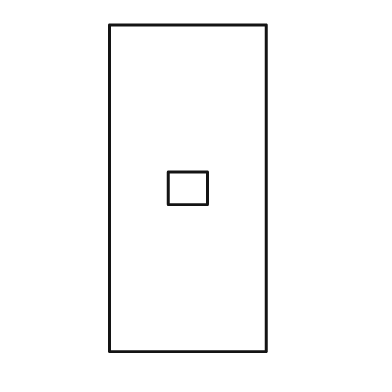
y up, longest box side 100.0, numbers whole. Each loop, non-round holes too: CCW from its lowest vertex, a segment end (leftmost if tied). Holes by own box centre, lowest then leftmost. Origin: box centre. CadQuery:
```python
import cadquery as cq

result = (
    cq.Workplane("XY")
    .moveTo(-24.0, -50.0)
    .lineTo(24.0, -50.0)
    .lineTo(24.0, 50.0)
    .lineTo(-24.0, 50.0)
    .close()
    .moveTo(-6.0, -5.0)
    .lineTo(6.0, -5.0)
    .lineTo(6.0, 5.0)
    .lineTo(-6.0, 5.0)
    .close()
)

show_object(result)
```